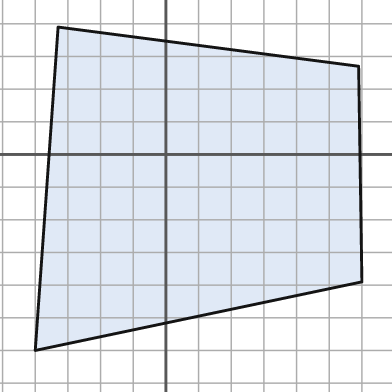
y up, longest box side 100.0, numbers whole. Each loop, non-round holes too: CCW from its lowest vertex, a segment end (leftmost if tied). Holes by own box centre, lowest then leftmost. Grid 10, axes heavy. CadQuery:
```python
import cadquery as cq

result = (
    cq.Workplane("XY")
    .moveTo(-40.0, -60.0)
    .lineTo(60.0, -39.0)
    .lineTo(59.0, 27.0)
    .lineTo(-33.0, 39.0)
    .close()
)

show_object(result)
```